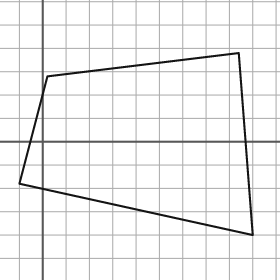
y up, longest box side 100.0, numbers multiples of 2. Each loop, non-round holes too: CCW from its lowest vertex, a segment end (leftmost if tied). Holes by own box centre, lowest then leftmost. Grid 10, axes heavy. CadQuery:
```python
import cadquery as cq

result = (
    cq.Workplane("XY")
    .moveTo(90.0, -40.0)
    .lineTo(84.0, 38.0)
    .lineTo(2.0, 28.0)
    .lineTo(-10.0, -18.0)
    .close()
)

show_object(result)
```